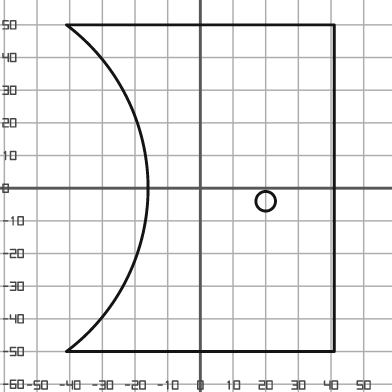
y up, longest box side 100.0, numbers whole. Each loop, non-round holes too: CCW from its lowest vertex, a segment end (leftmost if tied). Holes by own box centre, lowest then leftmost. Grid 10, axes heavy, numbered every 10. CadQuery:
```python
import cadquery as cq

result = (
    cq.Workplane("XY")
    .moveTo(-41.0, -50.0)
    .lineTo(41.0, -50.0)
    .lineTo(41.0, 50.0)
    .lineTo(-41.0, 50.0)
    .threePointArc((-16.0, 0.0), (-41.0, -50.0))
    .close()
    .moveTo(20.0, -4.0)
    .circle(3.0)
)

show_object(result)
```